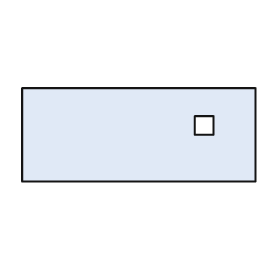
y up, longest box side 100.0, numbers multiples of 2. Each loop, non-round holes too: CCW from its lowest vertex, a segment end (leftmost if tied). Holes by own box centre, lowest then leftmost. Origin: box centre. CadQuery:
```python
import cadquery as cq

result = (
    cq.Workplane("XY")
    .moveTo(-50.0, -20.0)
    .lineTo(50.0, -20.0)
    .lineTo(50.0, 20.0)
    .lineTo(-50.0, 20.0)
    .close()
    .moveTo(24.0, 0.0)
    .lineTo(32.0, 0.0)
    .lineTo(32.0, 8.0)
    .lineTo(24.0, 8.0)
    .close()
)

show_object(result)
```